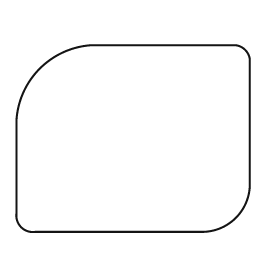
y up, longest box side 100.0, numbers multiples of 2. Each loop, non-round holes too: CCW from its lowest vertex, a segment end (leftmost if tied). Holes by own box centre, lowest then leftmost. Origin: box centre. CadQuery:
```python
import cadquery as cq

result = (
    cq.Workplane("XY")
    .moveTo(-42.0, -40.0)
    .lineTo(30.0, -40.0)
    .threePointArc((44.0, -34.0), (50.0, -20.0))
    .lineTo(50.0, 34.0)
    .threePointArc((48.0, 38.0), (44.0, 40.0))
    .lineTo(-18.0, 40.0)
    .threePointArc((-40.0, 30.0), (-50.0, 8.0))
    .lineTo(-50.0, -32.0)
    .threePointArc((-48.0, -38.0), (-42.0, -40.0))
    .close()
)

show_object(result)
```